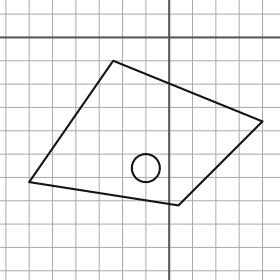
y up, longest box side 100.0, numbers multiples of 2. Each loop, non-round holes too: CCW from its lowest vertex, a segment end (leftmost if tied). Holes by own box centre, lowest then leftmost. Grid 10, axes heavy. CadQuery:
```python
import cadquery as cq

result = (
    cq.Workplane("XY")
    .moveTo(4.0, -72.0)
    .lineTo(40.0, -36.0)
    .lineTo(-24.0, -10.0)
    .lineTo(-60.0, -62.0)
    .close()
    .moveTo(-10.0, -56.0)
    .circle(6.0)
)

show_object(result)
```